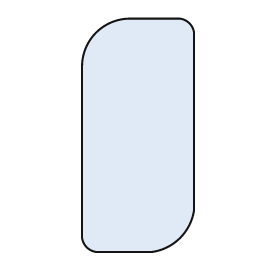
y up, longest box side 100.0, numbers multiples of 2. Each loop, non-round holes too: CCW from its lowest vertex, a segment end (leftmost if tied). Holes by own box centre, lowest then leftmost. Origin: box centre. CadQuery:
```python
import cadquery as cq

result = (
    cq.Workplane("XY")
    .moveTo(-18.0, -50.0)
    .lineTo(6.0, -50.0)
    .threePointArc((18.0, -44.0), (24.0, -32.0))
    .lineTo(24.0, 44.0)
    .threePointArc((22.0, 48.0), (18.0, 50.0))
    .lineTo(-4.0, 50.0)
    .threePointArc((-18.0, 44.0), (-24.0, 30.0))
    .lineTo(-24.0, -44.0)
    .threePointArc((-22.0, -48.0), (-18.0, -50.0))
    .close()
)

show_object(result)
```